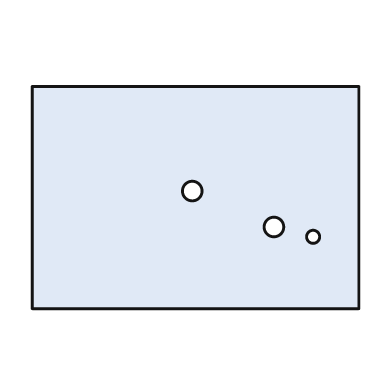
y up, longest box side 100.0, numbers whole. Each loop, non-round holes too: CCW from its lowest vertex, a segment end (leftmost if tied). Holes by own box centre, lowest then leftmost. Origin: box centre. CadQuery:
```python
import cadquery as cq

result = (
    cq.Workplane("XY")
    .moveTo(-50.0, -34.0)
    .lineTo(50.0, -34.0)
    .lineTo(50.0, 34.0)
    .lineTo(-50.0, 34.0)
    .close()
    .moveTo(36.0, -12.0)
    .circle(2.0)
    .moveTo(24.0, -9.0)
    .circle(3.0)
    .moveTo(-1.0, 2.0)
    .circle(3.0)
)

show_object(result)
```